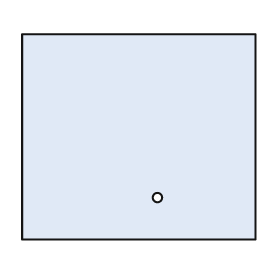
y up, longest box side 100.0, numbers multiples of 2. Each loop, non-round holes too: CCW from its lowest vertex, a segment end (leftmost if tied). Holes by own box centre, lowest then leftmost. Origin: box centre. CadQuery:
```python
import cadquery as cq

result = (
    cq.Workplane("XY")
    .moveTo(-50.0, -44.0)
    .lineTo(50.0, -44.0)
    .lineTo(50.0, 44.0)
    .lineTo(-50.0, 44.0)
    .close()
    .moveTo(8.0, -26.0)
    .circle(2.0)
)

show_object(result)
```